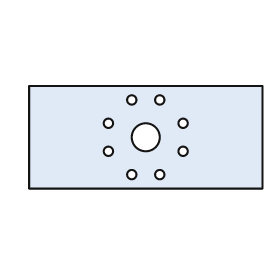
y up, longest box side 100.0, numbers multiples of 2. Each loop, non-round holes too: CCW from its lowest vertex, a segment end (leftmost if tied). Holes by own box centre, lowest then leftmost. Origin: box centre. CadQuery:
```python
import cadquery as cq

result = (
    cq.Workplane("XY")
    .moveTo(-50.0, -22.0)
    .lineTo(50.0, -22.0)
    .lineTo(50.0, 22.0)
    .lineTo(-50.0, 22.0)
    .close()
    .moveTo(-6.0, -16.0)
    .circle(2.0)
    .moveTo(6.0, -16.0)
    .circle(2.0)
    .moveTo(-16.0, -6.0)
    .circle(2.0)
    .moveTo(16.0, -6.0)
    .circle(2.0)
    .moveTo(0.0, 0.0)
    .circle(6.0)
    .moveTo(-16.0, 6.0)
    .circle(2.0)
    .moveTo(16.0, 6.0)
    .circle(2.0)
    .moveTo(-6.0, 16.0)
    .circle(2.0)
    .moveTo(6.0, 16.0)
    .circle(2.0)
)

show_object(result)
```